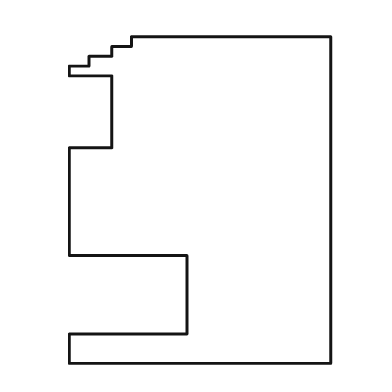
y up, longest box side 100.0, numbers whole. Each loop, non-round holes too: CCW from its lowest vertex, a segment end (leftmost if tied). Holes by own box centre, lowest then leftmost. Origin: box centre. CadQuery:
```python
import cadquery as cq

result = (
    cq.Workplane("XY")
    .moveTo(-40.0, -50.0)
    .lineTo(40.0, -50.0)
    .lineTo(40.0, 50.0)
    .lineTo(-21.0, 50.0)
    .lineTo(-21.0, 47.0)
    .lineTo(-27.0, 47.0)
    .lineTo(-27.0, 44.0)
    .lineTo(-34.0, 44.0)
    .lineTo(-34.0, 41.0)
    .lineTo(-40.0, 41.0)
    .lineTo(-40.0, 38.0)
    .lineTo(-27.0, 38.0)
    .lineTo(-27.0, 16.0)
    .lineTo(-40.0, 16.0)
    .lineTo(-40.0, -17.0)
    .lineTo(-4.0, -17.0)
    .lineTo(-4.0, -41.0)
    .lineTo(-40.0, -41.0)
    .close()
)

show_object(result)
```